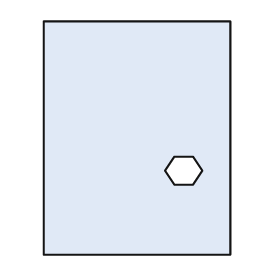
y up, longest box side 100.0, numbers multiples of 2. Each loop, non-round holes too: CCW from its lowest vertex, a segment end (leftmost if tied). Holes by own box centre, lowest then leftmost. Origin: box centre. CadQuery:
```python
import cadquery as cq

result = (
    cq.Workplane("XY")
    .moveTo(-40.0, -50.0)
    .lineTo(40.0, -50.0)
    .lineTo(40.0, 50.0)
    .lineTo(-40.0, 50.0)
    .close()
    .moveTo(16.0, -20.0)
    .lineTo(24.0, -20.0)
    .lineTo(28.0, -14.0)
    .lineTo(24.0, -8.0)
    .lineTo(16.0, -8.0)
    .lineTo(12.0, -14.0)
    .close()
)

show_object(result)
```